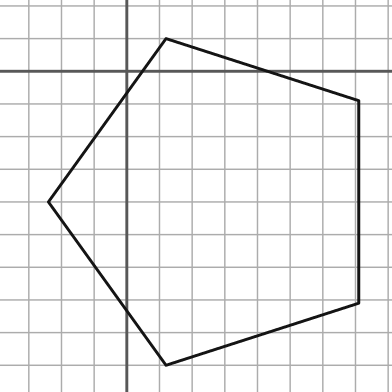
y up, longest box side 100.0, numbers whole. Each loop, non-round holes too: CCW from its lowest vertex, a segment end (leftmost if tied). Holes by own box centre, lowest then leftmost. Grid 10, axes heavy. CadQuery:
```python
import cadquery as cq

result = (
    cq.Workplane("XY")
    .moveTo(12.0, -90.0)
    .lineTo(71.0, -71.0)
    .lineTo(71.0, -9.0)
    .lineTo(12.0, 10.0)
    .lineTo(-24.0, -40.0)
    .close()
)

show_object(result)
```